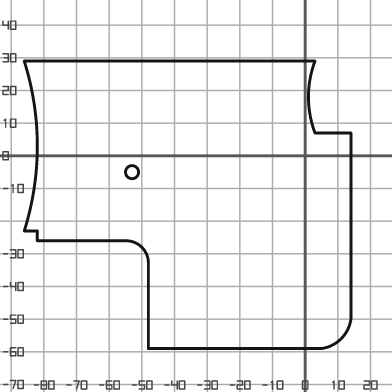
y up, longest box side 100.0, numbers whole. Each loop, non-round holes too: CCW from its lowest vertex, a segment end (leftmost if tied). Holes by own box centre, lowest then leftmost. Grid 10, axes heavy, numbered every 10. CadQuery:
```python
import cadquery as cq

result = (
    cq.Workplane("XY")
    .moveTo(-48.0, -59.0)
    .lineTo(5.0, -59.0)
    .threePointArc((11.0, -56.0), (14.0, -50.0))
    .lineTo(14.0, 7.0)
    .lineTo(3.0, 7.0)
    .threePointArc((1.0, 18.0), (3.0, 29.0))
    .lineTo(-86.0, 29.0)
    .threePointArc((-82.0, 3.0), (-86.0, -23.0))
    .lineTo(-82.0, -23.0)
    .lineTo(-82.0, -26.0)
    .lineTo(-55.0, -26.0)
    .threePointArc((-50.0, -28.0), (-48.0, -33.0))
    .close()
    .moveTo(-53.0, -5.0)
    .circle(2.0)
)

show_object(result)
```